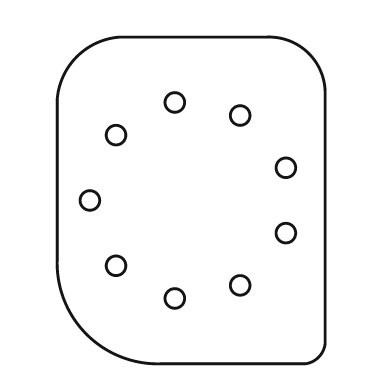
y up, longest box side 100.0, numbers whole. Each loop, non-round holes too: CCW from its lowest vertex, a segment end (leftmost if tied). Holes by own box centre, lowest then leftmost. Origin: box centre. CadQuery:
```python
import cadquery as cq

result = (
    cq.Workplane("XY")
    .moveTo(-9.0, -50.0)
    .lineTo(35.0, -50.0)
    .threePointArc((39.0, -48.0), (41.0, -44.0))
    .lineTo(41.0, 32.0)
    .threePointArc((36.0, 45.0), (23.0, 50.0))
    .lineTo(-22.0, 50.0)
    .threePointArc((-35.0, 44.0), (-41.0, 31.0))
    .lineTo(-41.0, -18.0)
    .threePointArc((-32.0, -41.0), (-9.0, -50.0))
    .close()
    .moveTo(-5.0, -30.0)
    .circle(3.0)
    .moveTo(15.0, -26.0)
    .circle(3.0)
    .moveTo(-23.0, -20.0)
    .circle(3.0)
    .moveTo(29.0, -10.0)
    .circle(3.0)
    .moveTo(-31.0, 0.0)
    .circle(3.0)
    .moveTo(29.0, 10.0)
    .circle(3.0)
    .moveTo(-23.0, 20.0)
    .circle(3.0)
    .moveTo(15.0, 26.0)
    .circle(3.0)
    .moveTo(-5.0, 30.0)
    .circle(3.0)
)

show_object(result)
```